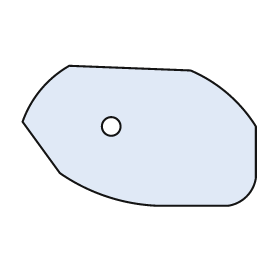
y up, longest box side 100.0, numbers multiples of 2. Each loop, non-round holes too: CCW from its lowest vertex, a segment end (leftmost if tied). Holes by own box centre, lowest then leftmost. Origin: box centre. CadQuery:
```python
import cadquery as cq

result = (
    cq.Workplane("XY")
    .moveTo(8.0, -30.0)
    .lineTo(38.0, -30.0)
    .threePointArc((46.0, -26.0), (50.0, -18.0))
    .lineTo(50.0, 4.0)
    .threePointArc((38.0, 18.0), (22.0, 28.0))
    .lineTo(-30.0, 30.0)
    .threePointArc((-42.0, 20.0), (-50.0, 6.0))
    .lineTo(-34.0, -16.0)
    .threePointArc((-14.0, -26.0), (8.0, -30.0))
    .close()
    .moveTo(-12.0, 4.0)
    .circle(4.0)
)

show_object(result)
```